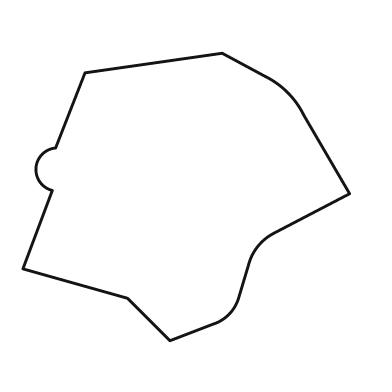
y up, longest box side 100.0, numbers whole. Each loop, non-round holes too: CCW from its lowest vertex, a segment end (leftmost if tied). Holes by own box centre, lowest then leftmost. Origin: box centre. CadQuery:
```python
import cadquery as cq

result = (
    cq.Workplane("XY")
    .moveTo(-5.0, -44.0)
    .lineTo(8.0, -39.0)
    .threePointArc((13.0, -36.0), (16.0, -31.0))
    .lineTo(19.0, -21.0)
    .threePointArc((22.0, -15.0), (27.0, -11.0))
    .lineTo(50.0, 1.0)
    .lineTo(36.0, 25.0)
    .threePointArc((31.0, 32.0), (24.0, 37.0))
    .lineTo(11.0, 44.0)
    .lineTo(-31.0, 38.0)
    .lineTo(-40.0, 15.0)
    .threePointArc((-46.0, 9.0), (-41.0, 2.0))
    .lineTo(-50.0, -22.0)
    .lineTo(-18.0, -31.0)
    .close()
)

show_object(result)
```